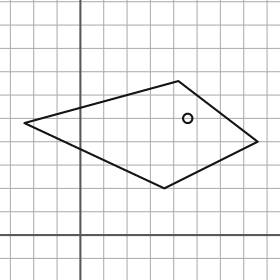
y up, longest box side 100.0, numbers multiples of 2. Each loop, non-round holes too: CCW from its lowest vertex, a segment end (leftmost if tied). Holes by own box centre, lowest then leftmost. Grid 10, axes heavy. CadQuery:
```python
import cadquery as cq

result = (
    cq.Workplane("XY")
    .moveTo(36.0, 20.0)
    .lineTo(76.0, 40.0)
    .lineTo(42.0, 66.0)
    .lineTo(-24.0, 48.0)
    .close()
    .moveTo(46.0, 50.0)
    .circle(2.0)
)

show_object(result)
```